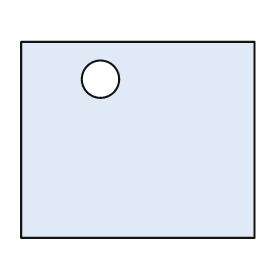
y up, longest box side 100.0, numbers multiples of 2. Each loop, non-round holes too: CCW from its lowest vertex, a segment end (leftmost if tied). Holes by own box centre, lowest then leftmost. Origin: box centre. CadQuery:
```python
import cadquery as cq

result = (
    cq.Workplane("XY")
    .moveTo(-50.0, -42.0)
    .lineTo(50.0, -42.0)
    .lineTo(50.0, 42.0)
    .lineTo(-50.0, 42.0)
    .close()
    .moveTo(-16.0, 26.0)
    .circle(8.0)
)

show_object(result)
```